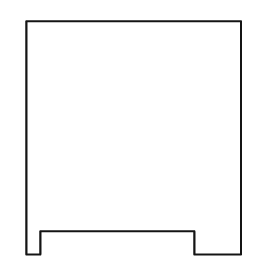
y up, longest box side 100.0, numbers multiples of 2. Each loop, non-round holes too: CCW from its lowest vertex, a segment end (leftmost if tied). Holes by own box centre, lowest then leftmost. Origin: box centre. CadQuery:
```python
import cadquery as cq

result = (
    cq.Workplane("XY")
    .moveTo(-46.0, -50.0)
    .lineTo(-40.0, -50.0)
    .lineTo(-40.0, -40.0)
    .lineTo(26.0, -40.0)
    .lineTo(26.0, -50.0)
    .lineTo(46.0, -50.0)
    .lineTo(46.0, 50.0)
    .lineTo(-46.0, 50.0)
    .close()
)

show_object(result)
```